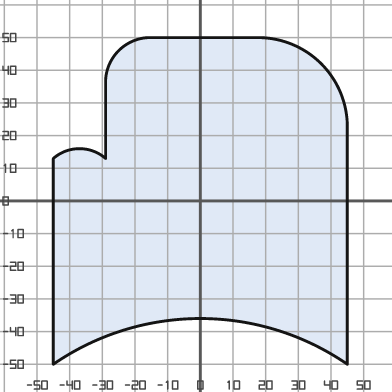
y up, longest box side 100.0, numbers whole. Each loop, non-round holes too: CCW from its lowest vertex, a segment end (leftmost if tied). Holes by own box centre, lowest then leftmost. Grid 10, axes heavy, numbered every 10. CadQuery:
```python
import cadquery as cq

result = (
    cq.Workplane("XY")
    .moveTo(-45.0, -50.0)
    .threePointArc((0.0, -36.0), (45.0, -50.0))
    .lineTo(45.0, 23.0)
    .threePointArc((37.0, 42.0), (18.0, 50.0))
    .lineTo(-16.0, 50.0)
    .threePointArc((-25.0, 46.0), (-29.0, 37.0))
    .lineTo(-29.0, 13.0)
    .threePointArc((-37.0, 16.0), (-45.0, 13.0))
    .close()
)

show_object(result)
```